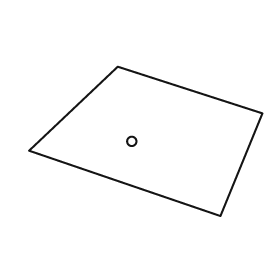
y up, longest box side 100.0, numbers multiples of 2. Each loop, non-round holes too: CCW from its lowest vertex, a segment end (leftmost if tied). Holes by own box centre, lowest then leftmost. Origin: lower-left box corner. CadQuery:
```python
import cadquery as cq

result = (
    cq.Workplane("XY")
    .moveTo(82.0, 0.0)
    .lineTo(100.0, 44.0)
    .lineTo(38.0, 64.0)
    .lineTo(0.0, 28.0)
    .close()
    .moveTo(44.0, 32.0)
    .circle(2.0)
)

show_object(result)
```